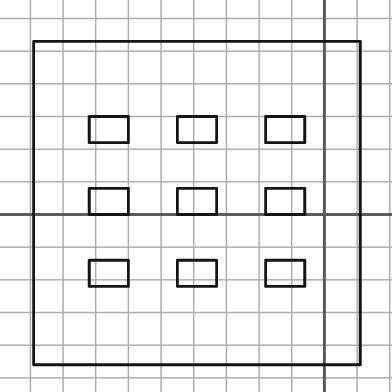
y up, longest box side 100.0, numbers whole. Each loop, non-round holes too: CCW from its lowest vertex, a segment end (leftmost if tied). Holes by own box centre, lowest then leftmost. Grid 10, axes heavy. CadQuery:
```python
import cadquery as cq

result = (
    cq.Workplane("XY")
    .moveTo(-89.0, -46.0)
    .lineTo(11.0, -46.0)
    .lineTo(11.0, 53.0)
    .lineTo(-89.0, 53.0)
    .close()
    .moveTo(-72.0, -22.0)
    .lineTo(-60.0, -22.0)
    .lineTo(-60.0, -14.0)
    .lineTo(-72.0, -14.0)
    .close()
    .moveTo(-45.0, -22.0)
    .lineTo(-33.0, -22.0)
    .lineTo(-33.0, -14.0)
    .lineTo(-45.0, -14.0)
    .close()
    .moveTo(-18.0, -22.0)
    .lineTo(-6.0, -22.0)
    .lineTo(-6.0, -14.0)
    .lineTo(-18.0, -14.0)
    .close()
    .moveTo(-72.0, 0.0)
    .lineTo(-60.0, 0.0)
    .lineTo(-60.0, 8.0)
    .lineTo(-72.0, 8.0)
    .close()
    .moveTo(-45.0, 0.0)
    .lineTo(-33.0, 0.0)
    .lineTo(-33.0, 8.0)
    .lineTo(-45.0, 8.0)
    .close()
    .moveTo(-18.0, 0.0)
    .lineTo(-6.0, 0.0)
    .lineTo(-6.0, 8.0)
    .lineTo(-18.0, 8.0)
    .close()
    .moveTo(-72.0, 22.0)
    .lineTo(-60.0, 22.0)
    .lineTo(-60.0, 30.0)
    .lineTo(-72.0, 30.0)
    .close()
    .moveTo(-45.0, 22.0)
    .lineTo(-33.0, 22.0)
    .lineTo(-33.0, 30.0)
    .lineTo(-45.0, 30.0)
    .close()
    .moveTo(-18.0, 22.0)
    .lineTo(-6.0, 22.0)
    .lineTo(-6.0, 30.0)
    .lineTo(-18.0, 30.0)
    .close()
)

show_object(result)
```